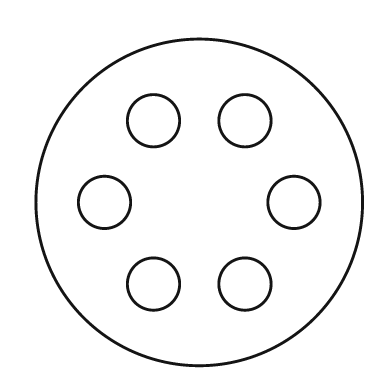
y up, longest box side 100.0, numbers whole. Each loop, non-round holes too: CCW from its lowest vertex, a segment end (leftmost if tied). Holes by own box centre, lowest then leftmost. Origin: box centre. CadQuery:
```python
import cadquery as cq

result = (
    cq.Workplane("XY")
    .moveTo(0.0, 0.0)
    .circle(50.0)
    .moveTo(-14.0, -25.0)
    .circle(8.0)
    .moveTo(14.0, -25.0)
    .circle(8.0)
    .moveTo(-29.0, 0.0)
    .circle(8.0)
    .moveTo(29.0, 0.0)
    .circle(8.0)
    .moveTo(-14.0, 25.0)
    .circle(8.0)
    .moveTo(14.0, 25.0)
    .circle(8.0)
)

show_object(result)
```